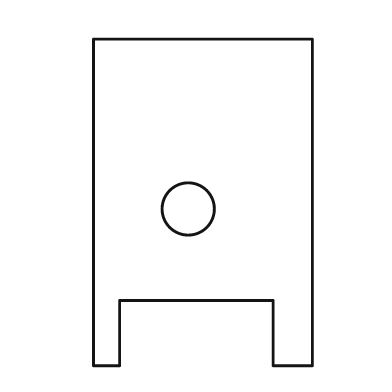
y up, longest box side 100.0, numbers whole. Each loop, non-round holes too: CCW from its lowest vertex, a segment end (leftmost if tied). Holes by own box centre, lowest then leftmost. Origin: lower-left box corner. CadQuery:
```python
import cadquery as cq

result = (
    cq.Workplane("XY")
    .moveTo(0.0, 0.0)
    .lineTo(8.0, 0.0)
    .lineTo(8.0, 20.0)
    .lineTo(55.0, 20.0)
    .lineTo(55.0, 0.0)
    .lineTo(67.0, 0.0)
    .lineTo(67.0, 100.0)
    .lineTo(0.0, 100.0)
    .close()
    .moveTo(29.0, 48.0)
    .circle(8.0)
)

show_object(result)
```